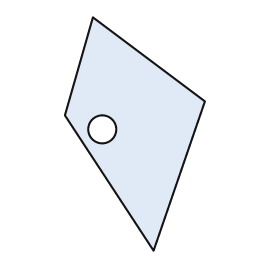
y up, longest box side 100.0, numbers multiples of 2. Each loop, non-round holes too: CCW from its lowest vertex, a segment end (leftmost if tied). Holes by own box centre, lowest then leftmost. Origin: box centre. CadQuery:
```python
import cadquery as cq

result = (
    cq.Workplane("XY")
    .moveTo(8.0, -50.0)
    .lineTo(30.0, 14.0)
    .lineTo(-18.0, 50.0)
    .lineTo(-30.0, 8.0)
    .close()
    .moveTo(-14.0, 2.0)
    .circle(6.0)
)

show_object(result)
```